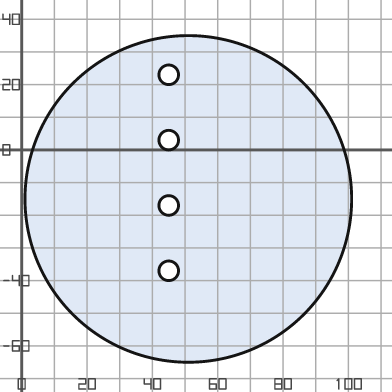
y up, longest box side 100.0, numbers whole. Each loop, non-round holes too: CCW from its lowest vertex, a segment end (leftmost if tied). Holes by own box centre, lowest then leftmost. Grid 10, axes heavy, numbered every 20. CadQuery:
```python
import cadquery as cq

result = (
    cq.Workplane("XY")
    .moveTo(51.0, -15.0)
    .circle(50.0)
    .moveTo(45.0, -37.0)
    .circle(3.0)
    .moveTo(45.0, -17.0)
    .circle(3.0)
    .moveTo(45.0, 3.0)
    .circle(3.0)
    .moveTo(45.0, 23.0)
    .circle(3.0)
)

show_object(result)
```